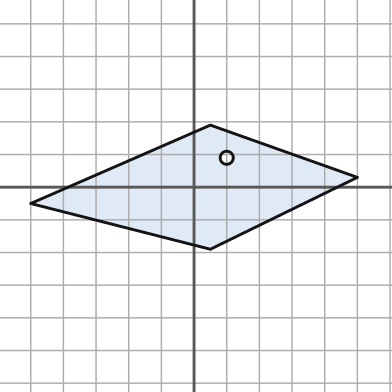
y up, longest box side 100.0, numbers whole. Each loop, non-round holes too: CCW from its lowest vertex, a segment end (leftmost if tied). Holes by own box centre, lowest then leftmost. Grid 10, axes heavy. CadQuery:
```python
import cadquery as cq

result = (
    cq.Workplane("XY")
    .moveTo(5.0, -19.0)
    .lineTo(50.0, 3.0)
    .lineTo(5.0, 19.0)
    .lineTo(-50.0, -5.0)
    .close()
    .moveTo(10.0, 9.0)
    .circle(2.0)
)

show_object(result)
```